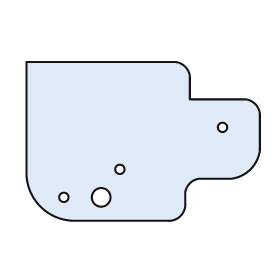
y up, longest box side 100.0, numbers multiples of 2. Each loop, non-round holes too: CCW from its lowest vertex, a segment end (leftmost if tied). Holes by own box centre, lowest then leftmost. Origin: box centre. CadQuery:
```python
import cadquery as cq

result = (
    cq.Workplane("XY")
    .moveTo(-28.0, -34.0)
    .lineTo(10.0, -34.0)
    .threePointArc((16.0, -32.0), (18.0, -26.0))
    .lineTo(18.0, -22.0)
    .threePointArc((20.0, -18.0), (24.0, -16.0))
    .lineTo(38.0, -16.0)
    .threePointArc((46.0, -12.0), (50.0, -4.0))
    .lineTo(50.0, 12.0)
    .threePointArc((48.0, 16.0), (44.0, 18.0))
    .lineTo(20.0, 18.0)
    .lineTo(20.0, 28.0)
    .threePointArc((18.0, 32.0), (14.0, 34.0))
    .lineTo(-50.0, 34.0)
    .lineTo(-50.0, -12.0)
    .threePointArc((-44.0, -28.0), (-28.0, -34.0))
    .close()
    .moveTo(-34.0, -24.0)
    .circle(2.0)
    .moveTo(-18.0, -24.0)
    .circle(4.0)
    .moveTo(-10.0, -12.0)
    .circle(2.0)
    .moveTo(34.0, 6.0)
    .circle(2.0)
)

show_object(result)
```